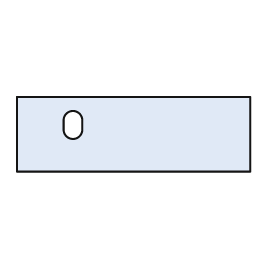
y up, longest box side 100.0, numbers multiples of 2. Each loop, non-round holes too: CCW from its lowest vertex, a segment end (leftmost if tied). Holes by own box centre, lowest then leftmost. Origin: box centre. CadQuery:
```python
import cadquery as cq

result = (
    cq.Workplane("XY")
    .moveTo(-50.0, -16.0)
    .lineTo(50.0, -16.0)
    .lineTo(50.0, 16.0)
    .lineTo(-50.0, 16.0)
    .close()
    .moveTo(-30.0, 2.0)
    .threePointArc((-26.0, -2.0), (-22.0, 2.0))
    .lineTo(-22.0, 6.0)
    .threePointArc((-26.0, 10.0), (-30.0, 6.0))
    .close()
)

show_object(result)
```